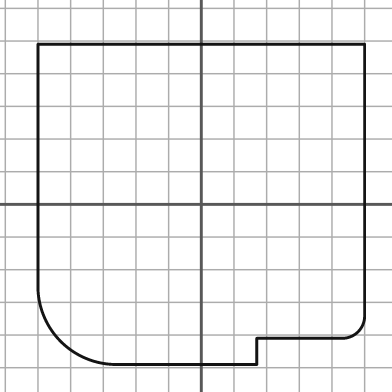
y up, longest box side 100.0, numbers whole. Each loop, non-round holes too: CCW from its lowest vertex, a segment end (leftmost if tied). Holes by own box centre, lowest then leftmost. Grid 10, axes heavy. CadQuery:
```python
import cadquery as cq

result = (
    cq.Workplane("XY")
    .moveTo(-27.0, -49.0)
    .lineTo(17.0, -49.0)
    .lineTo(17.0, -41.0)
    .lineTo(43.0, -41.0)
    .threePointArc((48.0, -39.0), (50.0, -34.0))
    .lineTo(50.0, 49.0)
    .lineTo(-50.0, 49.0)
    .lineTo(-50.0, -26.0)
    .threePointArc((-43.0, -42.0), (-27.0, -49.0))
    .close()
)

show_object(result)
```